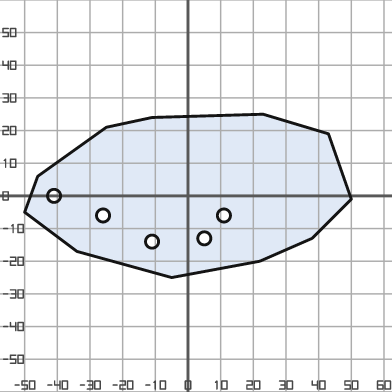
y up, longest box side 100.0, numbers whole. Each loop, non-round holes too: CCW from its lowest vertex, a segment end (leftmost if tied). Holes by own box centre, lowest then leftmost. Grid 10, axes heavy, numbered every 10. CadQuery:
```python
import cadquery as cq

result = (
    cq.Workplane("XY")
    .moveTo(-5.0, -25.0)
    .lineTo(22.0, -20.0)
    .lineTo(38.0, -13.0)
    .lineTo(50.0, -1.0)
    .lineTo(43.0, 19.0)
    .lineTo(23.0, 25.0)
    .lineTo(-11.0, 24.0)
    .lineTo(-25.0, 21.0)
    .lineTo(-46.0, 6.0)
    .lineTo(-50.0, -5.0)
    .lineTo(-34.0, -17.0)
    .close()
    .moveTo(-11.0, -14.0)
    .circle(2.0)
    .moveTo(5.0, -13.0)
    .circle(2.0)
    .moveTo(-26.0, -6.0)
    .circle(2.0)
    .moveTo(11.0, -6.0)
    .circle(2.0)
    .moveTo(-41.0, 0.0)
    .circle(2.0)
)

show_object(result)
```